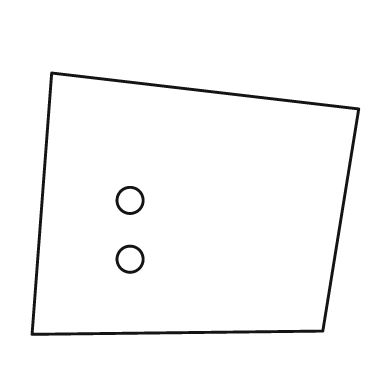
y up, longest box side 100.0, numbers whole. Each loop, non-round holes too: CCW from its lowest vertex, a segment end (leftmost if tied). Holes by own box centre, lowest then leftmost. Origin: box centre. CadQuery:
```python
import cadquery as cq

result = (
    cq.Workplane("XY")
    .moveTo(-50.0, -40.0)
    .lineTo(39.0, -39.0)
    .lineTo(50.0, 29.0)
    .lineTo(-44.0, 40.0)
    .close()
    .moveTo(-20.0, -17.0)
    .circle(4.0)
    .moveTo(-20.0, 1.0)
    .circle(4.0)
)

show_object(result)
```